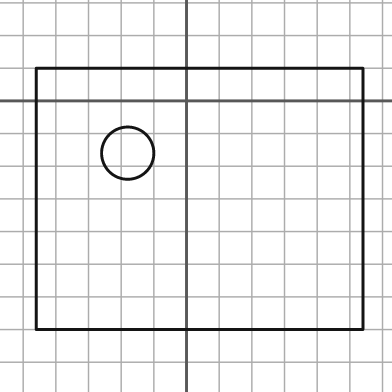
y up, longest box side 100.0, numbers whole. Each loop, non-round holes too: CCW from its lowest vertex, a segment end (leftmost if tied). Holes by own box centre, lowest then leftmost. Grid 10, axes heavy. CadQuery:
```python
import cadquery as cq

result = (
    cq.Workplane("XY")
    .moveTo(-46.0, -70.0)
    .lineTo(54.0, -70.0)
    .lineTo(54.0, 10.0)
    .lineTo(-46.0, 10.0)
    .close()
    .moveTo(-18.0, -16.0)
    .circle(8.0)
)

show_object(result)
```